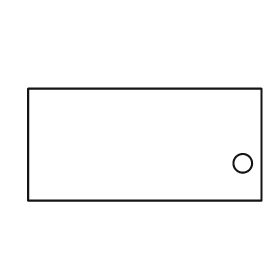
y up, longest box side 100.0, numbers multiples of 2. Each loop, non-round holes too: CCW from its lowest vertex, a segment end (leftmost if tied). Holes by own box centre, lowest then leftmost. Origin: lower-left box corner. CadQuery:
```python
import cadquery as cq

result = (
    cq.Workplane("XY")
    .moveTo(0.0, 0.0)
    .lineTo(100.0, 0.0)
    .lineTo(100.0, 48.0)
    .lineTo(0.0, 48.0)
    .close()
    .moveTo(92.0, 16.0)
    .circle(4.0)
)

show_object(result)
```